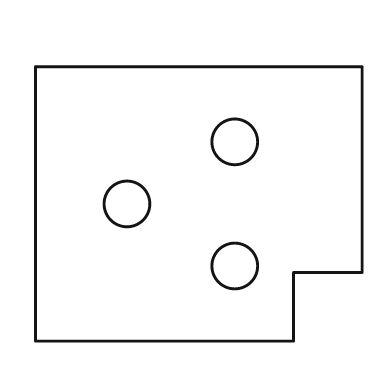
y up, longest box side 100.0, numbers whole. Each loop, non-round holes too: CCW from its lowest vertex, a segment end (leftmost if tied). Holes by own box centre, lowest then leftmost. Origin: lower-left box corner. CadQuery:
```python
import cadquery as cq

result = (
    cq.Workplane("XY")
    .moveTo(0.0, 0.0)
    .lineTo(79.0, 0.0)
    .lineTo(79.0, 21.0)
    .lineTo(100.0, 21.0)
    .lineTo(100.0, 84.0)
    .lineTo(0.0, 84.0)
    .close()
    .moveTo(61.0, 23.0)
    .circle(7.0)
    .moveTo(28.0, 42.0)
    .circle(7.0)
    .moveTo(61.0, 61.0)
    .circle(7.0)
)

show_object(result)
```